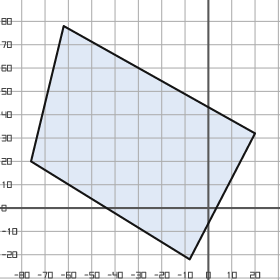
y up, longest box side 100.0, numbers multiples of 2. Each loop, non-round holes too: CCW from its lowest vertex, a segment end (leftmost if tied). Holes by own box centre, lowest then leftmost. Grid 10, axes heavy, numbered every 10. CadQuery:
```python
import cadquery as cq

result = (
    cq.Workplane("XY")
    .moveTo(-8.0, -22.0)
    .lineTo(20.0, 32.0)
    .lineTo(-62.0, 78.0)
    .lineTo(-76.0, 20.0)
    .close()
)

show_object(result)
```